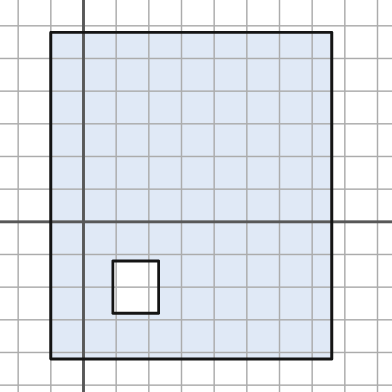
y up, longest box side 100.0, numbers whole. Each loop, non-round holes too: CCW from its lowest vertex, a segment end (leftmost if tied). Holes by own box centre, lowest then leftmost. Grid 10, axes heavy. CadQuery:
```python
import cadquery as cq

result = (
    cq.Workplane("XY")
    .moveTo(-10.0, -42.0)
    .lineTo(76.0, -42.0)
    .lineTo(76.0, 58.0)
    .lineTo(-10.0, 58.0)
    .close()
    .moveTo(9.0, -28.0)
    .lineTo(23.0, -28.0)
    .lineTo(23.0, -12.0)
    .lineTo(9.0, -12.0)
    .close()
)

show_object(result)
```